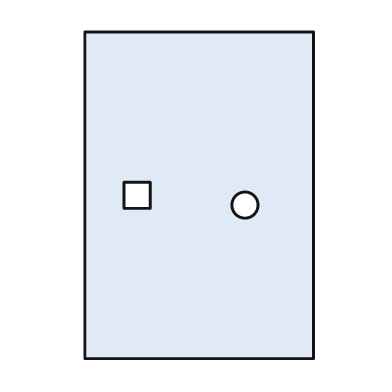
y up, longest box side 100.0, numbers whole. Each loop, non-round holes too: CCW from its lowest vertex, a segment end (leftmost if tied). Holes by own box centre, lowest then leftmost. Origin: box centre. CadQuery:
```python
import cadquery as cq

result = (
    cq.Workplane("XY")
    .moveTo(-35.0, -50.0)
    .lineTo(35.0, -50.0)
    .lineTo(35.0, 50.0)
    .lineTo(-35.0, 50.0)
    .close()
    .moveTo(14.0, -3.0)
    .circle(4.0)
    .moveTo(-23.0, -4.0)
    .lineTo(-15.0, -4.0)
    .lineTo(-15.0, 4.0)
    .lineTo(-23.0, 4.0)
    .close()
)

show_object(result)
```